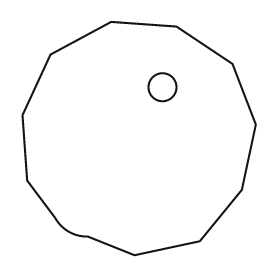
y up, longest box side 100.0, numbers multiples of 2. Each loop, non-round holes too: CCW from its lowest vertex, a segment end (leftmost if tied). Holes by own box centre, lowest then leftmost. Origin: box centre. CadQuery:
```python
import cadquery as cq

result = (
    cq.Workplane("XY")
    .moveTo(-2.0, -50.0)
    .lineTo(26.0, -44.0)
    .lineTo(44.0, -22.0)
    .lineTo(50.0, 6.0)
    .lineTo(40.0, 32.0)
    .lineTo(16.0, 48.0)
    .lineTo(-12.0, 50.0)
    .lineTo(-38.0, 36.0)
    .lineTo(-50.0, 10.0)
    .lineTo(-48.0, -18.0)
    .lineTo(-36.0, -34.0)
    .threePointArc((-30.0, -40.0), (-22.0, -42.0))
    .close()
    .moveTo(10.0, 22.0)
    .circle(6.0)
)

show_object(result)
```